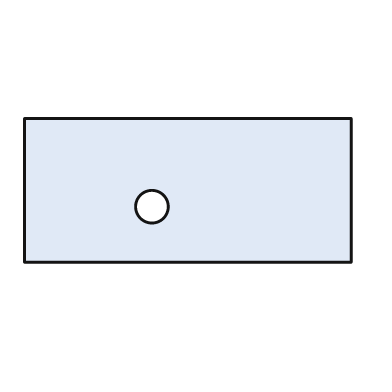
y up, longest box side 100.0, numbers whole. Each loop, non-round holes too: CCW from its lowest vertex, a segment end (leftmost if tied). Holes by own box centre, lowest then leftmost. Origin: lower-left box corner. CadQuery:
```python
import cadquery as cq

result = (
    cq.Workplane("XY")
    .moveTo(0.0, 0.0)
    .lineTo(100.0, 0.0)
    .lineTo(100.0, 44.0)
    .lineTo(0.0, 44.0)
    .close()
    .moveTo(39.0, 17.0)
    .circle(5.0)
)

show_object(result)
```